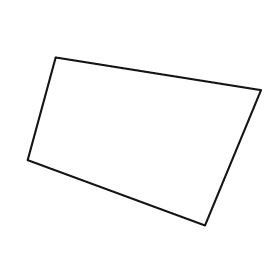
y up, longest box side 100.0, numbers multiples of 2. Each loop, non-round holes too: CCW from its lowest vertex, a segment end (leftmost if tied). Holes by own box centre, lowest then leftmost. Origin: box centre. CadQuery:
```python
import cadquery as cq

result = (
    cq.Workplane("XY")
    .moveTo(26.0, -36.0)
    .lineTo(50.0, 22.0)
    .lineTo(-38.0, 36.0)
    .lineTo(-50.0, -8.0)
    .close()
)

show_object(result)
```